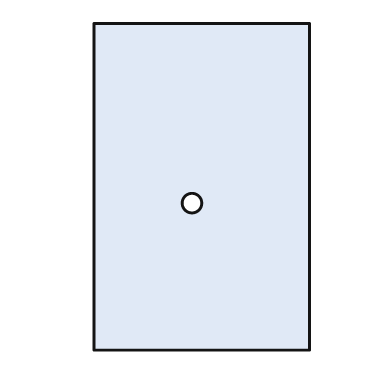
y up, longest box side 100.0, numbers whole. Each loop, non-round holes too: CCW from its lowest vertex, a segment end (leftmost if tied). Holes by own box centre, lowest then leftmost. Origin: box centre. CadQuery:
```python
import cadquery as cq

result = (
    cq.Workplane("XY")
    .moveTo(-33.0, -50.0)
    .lineTo(33.0, -50.0)
    .lineTo(33.0, 50.0)
    .lineTo(-33.0, 50.0)
    .close()
    .moveTo(-3.0, -5.0)
    .circle(3.0)
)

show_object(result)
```